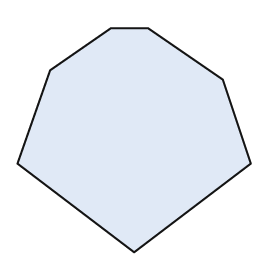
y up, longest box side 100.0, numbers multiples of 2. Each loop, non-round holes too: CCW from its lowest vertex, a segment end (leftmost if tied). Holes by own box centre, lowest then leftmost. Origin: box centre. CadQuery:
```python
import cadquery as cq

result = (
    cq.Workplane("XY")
    .moveTo(0.0, -48.0)
    .lineTo(50.0, -10.0)
    .lineTo(38.0, 26.0)
    .lineTo(6.0, 48.0)
    .lineTo(-10.0, 48.0)
    .lineTo(-36.0, 30.0)
    .lineTo(-50.0, -10.0)
    .close()
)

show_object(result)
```